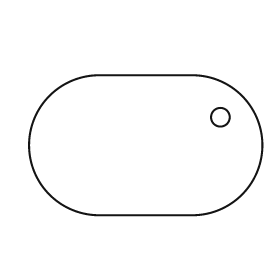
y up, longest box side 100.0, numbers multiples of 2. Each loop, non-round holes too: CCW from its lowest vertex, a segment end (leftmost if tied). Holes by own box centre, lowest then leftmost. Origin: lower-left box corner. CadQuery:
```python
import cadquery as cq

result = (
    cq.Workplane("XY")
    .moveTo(30.0, 0.0)
    .lineTo(70.0, 0.0)
    .threePointArc((100.0, 30.0), (70.0, 60.0))
    .lineTo(30.0, 60.0)
    .threePointArc((0.0, 30.0), (30.0, 0.0))
    .close()
    .moveTo(82.0, 42.0)
    .circle(4.0)
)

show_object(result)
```